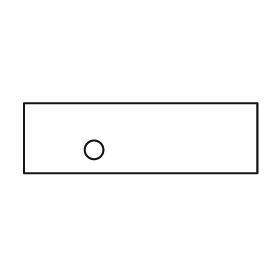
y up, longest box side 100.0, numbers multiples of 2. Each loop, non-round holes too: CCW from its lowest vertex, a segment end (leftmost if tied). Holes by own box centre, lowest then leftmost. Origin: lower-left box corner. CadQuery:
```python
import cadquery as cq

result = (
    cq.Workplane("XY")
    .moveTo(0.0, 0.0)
    .lineTo(100.0, 0.0)
    .lineTo(100.0, 30.0)
    .lineTo(0.0, 30.0)
    .close()
    .moveTo(30.0, 10.0)
    .circle(4.0)
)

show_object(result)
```